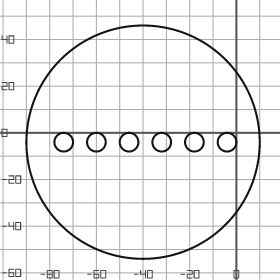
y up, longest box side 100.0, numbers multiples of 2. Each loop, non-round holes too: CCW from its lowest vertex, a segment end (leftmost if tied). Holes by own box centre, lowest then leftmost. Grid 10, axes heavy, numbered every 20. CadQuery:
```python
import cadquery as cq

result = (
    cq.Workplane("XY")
    .moveTo(-40.0, -4.0)
    .circle(50.0)
    .moveTo(-74.0, -4.0)
    .circle(4.0)
    .moveTo(-60.0, -4.0)
    .circle(4.0)
    .moveTo(-46.0, -4.0)
    .circle(4.0)
    .moveTo(-32.0, -4.0)
    .circle(4.0)
    .moveTo(-18.0, -4.0)
    .circle(4.0)
    .moveTo(-4.0, -4.0)
    .circle(4.0)
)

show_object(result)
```